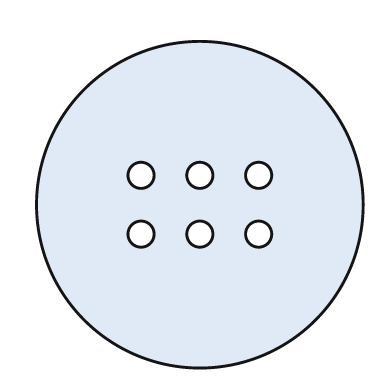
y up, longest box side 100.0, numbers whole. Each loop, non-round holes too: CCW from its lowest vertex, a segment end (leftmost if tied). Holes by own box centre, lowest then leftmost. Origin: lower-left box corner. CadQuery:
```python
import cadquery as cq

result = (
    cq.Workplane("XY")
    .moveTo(50.0, 50.0)
    .circle(50.0)
    .moveTo(32.0, 41.0)
    .circle(4.0)
    .moveTo(50.0, 41.0)
    .circle(4.0)
    .moveTo(68.0, 41.0)
    .circle(4.0)
    .moveTo(32.0, 59.0)
    .circle(4.0)
    .moveTo(50.0, 59.0)
    .circle(4.0)
    .moveTo(68.0, 59.0)
    .circle(4.0)
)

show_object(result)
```